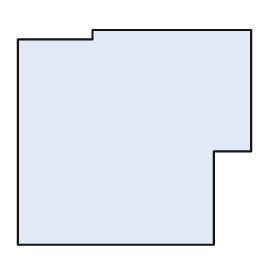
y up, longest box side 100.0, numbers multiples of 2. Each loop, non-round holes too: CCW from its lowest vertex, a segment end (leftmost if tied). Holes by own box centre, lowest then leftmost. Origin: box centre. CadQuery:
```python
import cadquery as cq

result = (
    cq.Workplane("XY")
    .moveTo(-50.0, -46.0)
    .lineTo(34.0, -46.0)
    .lineTo(34.0, -6.0)
    .lineTo(50.0, -6.0)
    .lineTo(50.0, 46.0)
    .lineTo(-18.0, 46.0)
    .lineTo(-18.0, 42.0)
    .lineTo(-50.0, 42.0)
    .close()
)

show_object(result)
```